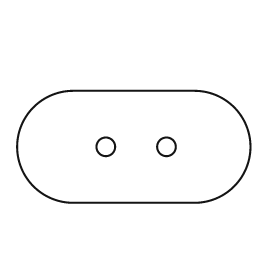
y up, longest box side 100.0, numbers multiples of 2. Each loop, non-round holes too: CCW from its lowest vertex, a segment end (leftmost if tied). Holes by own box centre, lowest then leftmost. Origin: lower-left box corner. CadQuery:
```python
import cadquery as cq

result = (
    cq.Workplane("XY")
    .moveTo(24.0, 0.0)
    .lineTo(76.0, 0.0)
    .threePointArc((100.0, 24.0), (76.0, 48.0))
    .lineTo(24.0, 48.0)
    .threePointArc((0.0, 24.0), (24.0, 0.0))
    .close()
    .moveTo(38.0, 24.0)
    .circle(4.0)
    .moveTo(64.0, 24.0)
    .circle(4.0)
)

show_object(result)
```